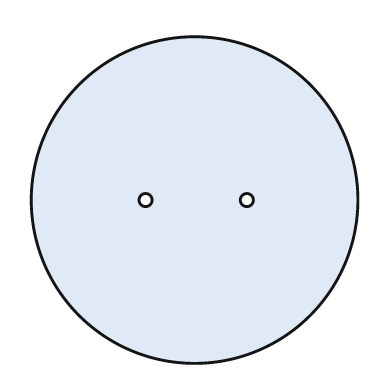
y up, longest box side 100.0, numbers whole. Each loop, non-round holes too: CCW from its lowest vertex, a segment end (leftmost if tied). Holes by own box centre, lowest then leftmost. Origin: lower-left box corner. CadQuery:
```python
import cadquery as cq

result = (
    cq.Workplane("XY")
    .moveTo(50.0, 50.0)
    .circle(50.0)
    .moveTo(35.0, 50.0)
    .circle(2.0)
    .moveTo(66.0, 50.0)
    .circle(2.0)
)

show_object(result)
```